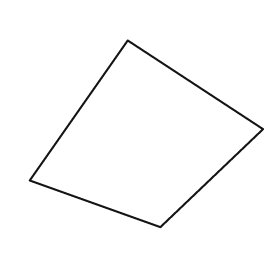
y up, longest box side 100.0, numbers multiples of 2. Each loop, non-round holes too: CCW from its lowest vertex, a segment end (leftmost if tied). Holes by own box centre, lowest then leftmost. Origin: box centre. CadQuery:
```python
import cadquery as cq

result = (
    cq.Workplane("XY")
    .moveTo(6.0, -40.0)
    .lineTo(50.0, 2.0)
    .lineTo(-8.0, 40.0)
    .lineTo(-50.0, -20.0)
    .close()
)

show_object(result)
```